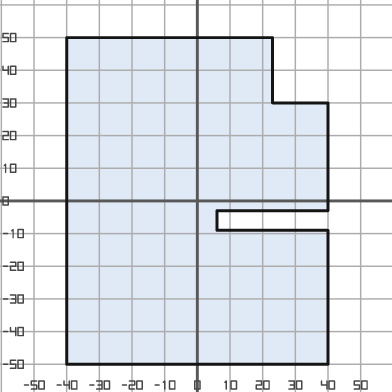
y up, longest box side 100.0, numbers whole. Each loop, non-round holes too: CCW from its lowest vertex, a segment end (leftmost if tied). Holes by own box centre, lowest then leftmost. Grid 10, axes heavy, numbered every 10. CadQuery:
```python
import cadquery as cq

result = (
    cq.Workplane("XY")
    .moveTo(-40.0, -50.0)
    .lineTo(40.0, -50.0)
    .lineTo(40.0, -9.0)
    .lineTo(6.0, -9.0)
    .lineTo(6.0, -3.0)
    .lineTo(40.0, -3.0)
    .lineTo(40.0, 30.0)
    .lineTo(23.0, 30.0)
    .lineTo(23.0, 50.0)
    .lineTo(-40.0, 50.0)
    .close()
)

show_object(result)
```